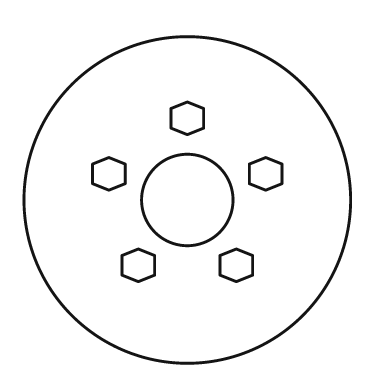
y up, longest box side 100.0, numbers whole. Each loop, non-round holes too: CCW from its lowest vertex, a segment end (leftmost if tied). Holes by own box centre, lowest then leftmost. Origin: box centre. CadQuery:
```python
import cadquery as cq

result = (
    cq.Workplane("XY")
    .moveTo(0.0, 0.0)
    .circle(50.0)
    .moveTo(-15.0, -25.0)
    .lineTo(-10.0, -23.0)
    .lineTo(-10.0, -17.0)
    .lineTo(-15.0, -15.0)
    .lineTo(-20.0, -17.0)
    .lineTo(-20.0, -23.0)
    .close()
    .moveTo(15.0, -25.0)
    .lineTo(20.0, -23.0)
    .lineTo(20.0, -17.0)
    .lineTo(15.0, -15.0)
    .lineTo(10.0, -17.0)
    .lineTo(10.0, -23.0)
    .close()
    .moveTo(0.0, 0.0)
    .circle(14.0)
    .moveTo(-24.0, 3.0)
    .lineTo(-19.0, 5.0)
    .lineTo(-19.0, 11.0)
    .lineTo(-24.0, 13.0)
    .lineTo(-29.0, 11.0)
    .lineTo(-29.0, 5.0)
    .close()
    .moveTo(24.0, 3.0)
    .lineTo(29.0, 5.0)
    .lineTo(29.0, 11.0)
    .lineTo(24.0, 13.0)
    .lineTo(19.0, 11.0)
    .lineTo(19.0, 5.0)
    .close()
    .moveTo(0.0, 20.0)
    .lineTo(5.0, 22.0)
    .lineTo(5.0, 28.0)
    .lineTo(0.0, 30.0)
    .lineTo(-5.0, 28.0)
    .lineTo(-5.0, 22.0)
    .close()
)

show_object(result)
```